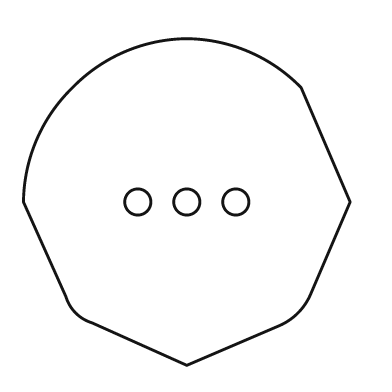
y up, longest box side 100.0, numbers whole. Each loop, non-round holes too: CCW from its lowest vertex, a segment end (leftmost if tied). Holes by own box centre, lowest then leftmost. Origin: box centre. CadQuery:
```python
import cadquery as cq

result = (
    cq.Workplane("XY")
    .moveTo(0.0, -50.0)
    .lineTo(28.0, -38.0)
    .threePointArc((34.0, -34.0), (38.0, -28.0))
    .lineTo(50.0, 0.0)
    .lineTo(35.0, 35.0)
    .threePointArc((19.0, 46.0), (0.0, 50.0))
    .threePointArc((-19.0, 46.0), (-35.0, 35.0))
    .threePointArc((-46.0, 19.0), (-50.0, 0.0))
    .lineTo(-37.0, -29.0)
    .threePointArc((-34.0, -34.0), (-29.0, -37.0))
    .close()
    .moveTo(-15.0, 0.0)
    .circle(4.0)
    .moveTo(0.0, 0.0)
    .circle(4.0)
    .moveTo(15.0, 0.0)
    .circle(4.0)
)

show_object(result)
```